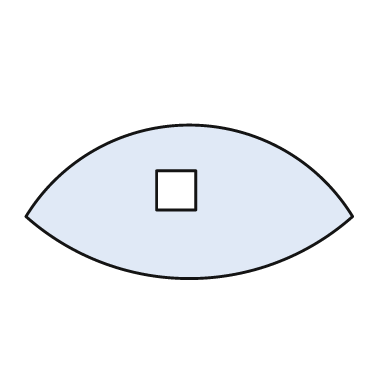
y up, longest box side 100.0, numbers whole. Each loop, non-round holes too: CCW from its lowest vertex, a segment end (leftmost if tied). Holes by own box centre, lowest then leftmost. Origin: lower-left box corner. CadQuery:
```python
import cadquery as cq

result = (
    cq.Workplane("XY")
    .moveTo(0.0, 19.0)
    .threePointArc((50.0, 0.0), (100.0, 19.0))
    .threePointArc((50.0, 47.0), (0.0, 19.0))
    .close()
    .moveTo(40.0, 21.0)
    .lineTo(52.0, 21.0)
    .lineTo(52.0, 33.0)
    .lineTo(40.0, 33.0)
    .close()
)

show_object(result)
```